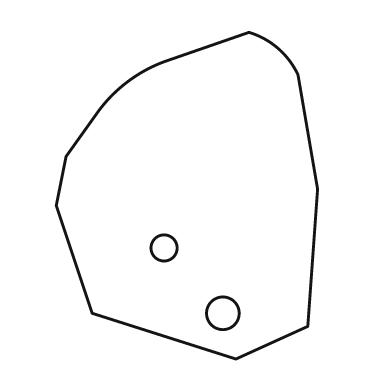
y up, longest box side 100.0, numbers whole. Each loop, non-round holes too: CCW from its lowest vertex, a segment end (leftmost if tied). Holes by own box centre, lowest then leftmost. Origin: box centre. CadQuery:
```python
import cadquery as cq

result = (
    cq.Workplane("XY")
    .moveTo(15.0, -50.0)
    .lineTo(37.0, -40.0)
    .lineTo(40.0, 2.0)
    .lineTo(34.0, 37.0)
    .threePointArc((28.0, 45.0), (19.0, 50.0))
    .lineTo(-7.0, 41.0)
    .threePointArc((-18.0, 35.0), (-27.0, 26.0))
    .lineTo(-37.0, 12.0)
    .lineTo(-40.0, -3.0)
    .lineTo(-29.0, -36.0)
    .close()
    .moveTo(11.0, -36.0)
    .circle(5.0)
    .moveTo(-7.0, -16.0)
    .circle(4.0)
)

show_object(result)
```